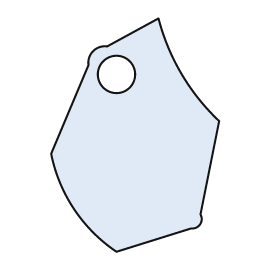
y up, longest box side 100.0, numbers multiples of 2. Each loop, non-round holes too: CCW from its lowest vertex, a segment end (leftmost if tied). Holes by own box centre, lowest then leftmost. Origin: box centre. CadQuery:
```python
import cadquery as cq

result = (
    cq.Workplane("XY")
    .moveTo(-8.0, -50.0)
    .lineTo(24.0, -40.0)
    .threePointArc((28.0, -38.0), (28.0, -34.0))
    .lineTo(36.0, 6.0)
    .threePointArc((20.0, 26.0), (10.0, 50.0))
    .lineTo(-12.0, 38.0)
    .threePointArc((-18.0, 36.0), (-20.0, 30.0))
    .lineTo(-36.0, -8.0)
    .threePointArc((-26.0, -32.0), (-8.0, -50.0))
    .close()
    .moveTo(-8.0, 26.0)
    .circle(8.0)
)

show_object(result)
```